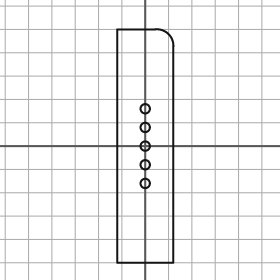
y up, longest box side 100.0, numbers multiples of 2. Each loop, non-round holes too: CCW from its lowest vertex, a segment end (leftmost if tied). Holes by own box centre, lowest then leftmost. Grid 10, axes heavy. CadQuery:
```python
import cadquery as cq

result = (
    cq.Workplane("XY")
    .moveTo(-12.0, -50.0)
    .lineTo(12.0, -50.0)
    .lineTo(12.0, 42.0)
    .threePointArc((10.0, 48.0), (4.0, 50.0))
    .lineTo(-12.0, 50.0)
    .close()
    .moveTo(0.0, -16.0)
    .circle(2.0)
    .moveTo(0.0, -8.0)
    .circle(2.0)
    .moveTo(0.0, 0.0)
    .circle(2.0)
    .moveTo(0.0, 8.0)
    .circle(2.0)
    .moveTo(0.0, 16.0)
    .circle(2.0)
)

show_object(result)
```